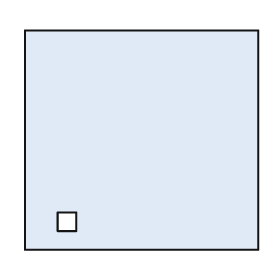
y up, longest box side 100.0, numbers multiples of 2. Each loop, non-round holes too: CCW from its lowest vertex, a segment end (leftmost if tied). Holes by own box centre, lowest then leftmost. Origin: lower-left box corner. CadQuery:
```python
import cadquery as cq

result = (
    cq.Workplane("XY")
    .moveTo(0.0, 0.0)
    .lineTo(100.0, 0.0)
    .lineTo(100.0, 94.0)
    .lineTo(0.0, 94.0)
    .close()
    .moveTo(14.0, 8.0)
    .lineTo(22.0, 8.0)
    .lineTo(22.0, 16.0)
    .lineTo(14.0, 16.0)
    .close()
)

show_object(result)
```